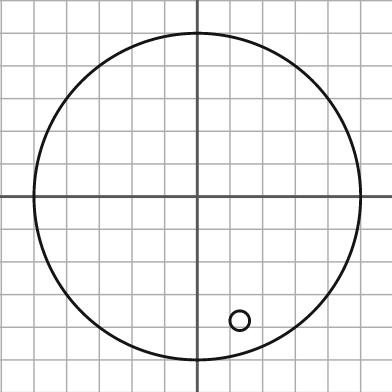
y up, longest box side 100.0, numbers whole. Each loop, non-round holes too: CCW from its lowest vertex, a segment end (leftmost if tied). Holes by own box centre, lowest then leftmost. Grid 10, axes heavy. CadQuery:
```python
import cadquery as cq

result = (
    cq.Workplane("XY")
    .moveTo(0.0, 0.0)
    .circle(50.0)
    .moveTo(13.0, -38.0)
    .circle(3.0)
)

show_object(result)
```